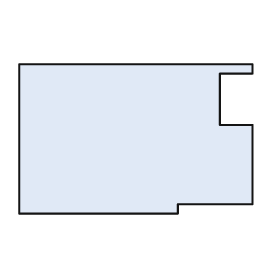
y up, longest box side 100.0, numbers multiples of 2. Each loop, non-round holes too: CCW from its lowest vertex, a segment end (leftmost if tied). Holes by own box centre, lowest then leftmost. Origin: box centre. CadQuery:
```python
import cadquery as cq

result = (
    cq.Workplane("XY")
    .moveTo(-50.0, -32.0)
    .lineTo(18.0, -32.0)
    .lineTo(18.0, -28.0)
    .lineTo(50.0, -28.0)
    .lineTo(50.0, 6.0)
    .lineTo(36.0, 6.0)
    .lineTo(36.0, 28.0)
    .lineTo(50.0, 28.0)
    .lineTo(50.0, 32.0)
    .lineTo(-50.0, 32.0)
    .close()
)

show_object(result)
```